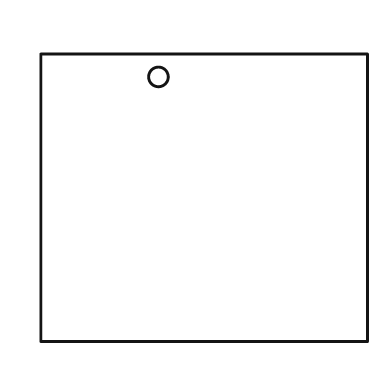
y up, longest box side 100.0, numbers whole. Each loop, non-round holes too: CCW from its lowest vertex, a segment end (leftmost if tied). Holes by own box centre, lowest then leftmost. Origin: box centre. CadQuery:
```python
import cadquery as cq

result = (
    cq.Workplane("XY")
    .moveTo(-50.0, -44.0)
    .lineTo(50.0, -44.0)
    .lineTo(50.0, 44.0)
    .lineTo(-50.0, 44.0)
    .close()
    .moveTo(-14.0, 37.0)
    .circle(3.0)
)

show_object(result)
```